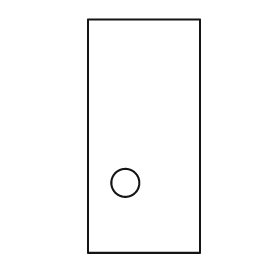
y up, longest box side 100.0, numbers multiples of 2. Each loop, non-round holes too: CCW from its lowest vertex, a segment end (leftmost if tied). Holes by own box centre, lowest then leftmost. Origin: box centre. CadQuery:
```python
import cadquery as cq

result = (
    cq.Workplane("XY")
    .moveTo(-24.0, -50.0)
    .lineTo(24.0, -50.0)
    .lineTo(24.0, 50.0)
    .lineTo(-24.0, 50.0)
    .close()
    .moveTo(-8.0, -20.0)
    .circle(6.0)
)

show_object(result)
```